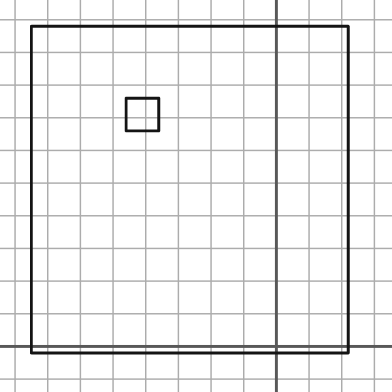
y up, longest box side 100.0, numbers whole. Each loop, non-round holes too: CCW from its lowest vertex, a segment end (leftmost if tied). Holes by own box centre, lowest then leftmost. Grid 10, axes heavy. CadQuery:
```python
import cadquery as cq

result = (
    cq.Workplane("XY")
    .moveTo(-75.0, -2.0)
    .lineTo(22.0, -2.0)
    .lineTo(22.0, 98.0)
    .lineTo(-75.0, 98.0)
    .close()
    .moveTo(-46.0, 66.0)
    .lineTo(-36.0, 66.0)
    .lineTo(-36.0, 76.0)
    .lineTo(-46.0, 76.0)
    .close()
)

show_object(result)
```